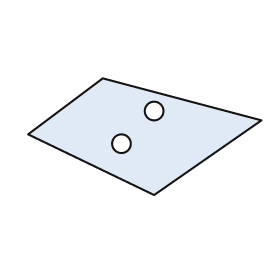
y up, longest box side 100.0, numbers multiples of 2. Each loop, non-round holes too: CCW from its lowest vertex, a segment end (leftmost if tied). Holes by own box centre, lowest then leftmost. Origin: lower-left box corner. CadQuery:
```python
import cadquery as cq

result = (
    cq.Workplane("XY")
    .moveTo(54.0, 0.0)
    .lineTo(100.0, 32.0)
    .lineTo(32.0, 50.0)
    .lineTo(0.0, 26.0)
    .close()
    .moveTo(40.0, 22.0)
    .circle(4.0)
    .moveTo(54.0, 36.0)
    .circle(4.0)
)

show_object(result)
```